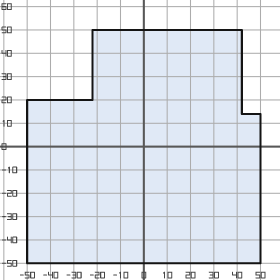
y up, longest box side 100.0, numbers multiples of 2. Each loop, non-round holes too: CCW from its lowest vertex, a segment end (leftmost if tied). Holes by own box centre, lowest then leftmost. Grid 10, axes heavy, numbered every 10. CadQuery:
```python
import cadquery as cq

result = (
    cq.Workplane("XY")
    .moveTo(-50.0, -50.0)
    .lineTo(50.0, -50.0)
    .lineTo(50.0, 14.0)
    .lineTo(42.0, 14.0)
    .lineTo(42.0, 50.0)
    .lineTo(-22.0, 50.0)
    .lineTo(-22.0, 20.0)
    .lineTo(-50.0, 20.0)
    .close()
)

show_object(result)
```